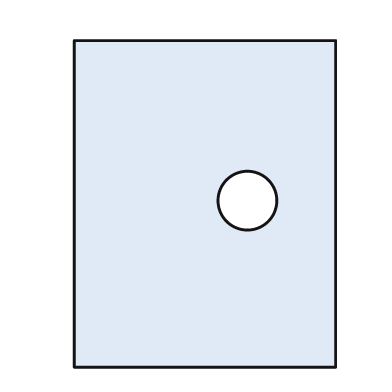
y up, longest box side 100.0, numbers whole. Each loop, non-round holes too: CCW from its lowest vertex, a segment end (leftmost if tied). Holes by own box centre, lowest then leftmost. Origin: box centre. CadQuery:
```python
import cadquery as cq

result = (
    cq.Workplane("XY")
    .moveTo(-40.0, -50.0)
    .lineTo(40.0, -50.0)
    .lineTo(40.0, 50.0)
    .lineTo(-40.0, 50.0)
    .close()
    .moveTo(13.0, 1.0)
    .circle(9.0)
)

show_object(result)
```